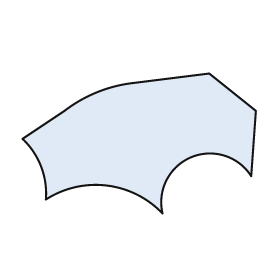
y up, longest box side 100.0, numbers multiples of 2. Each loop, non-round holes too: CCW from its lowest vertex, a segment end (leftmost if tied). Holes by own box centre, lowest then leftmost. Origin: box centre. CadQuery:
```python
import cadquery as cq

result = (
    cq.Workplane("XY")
    .moveTo(10.0, -30.0)
    .threePointArc((22.0, -6.0), (48.0, -14.0))
    .lineTo(50.0, 14.0)
    .lineTo(30.0, 30.0)
    .lineTo(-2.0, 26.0)
    .threePointArc((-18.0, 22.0), (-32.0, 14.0))
    .lineTo(-50.0, 2.0)
    .threePointArc((-42.0, -10.0), (-40.0, -24.0))
    .threePointArc((-14.0, -18.0), (10.0, -30.0))
    .close()
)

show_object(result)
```